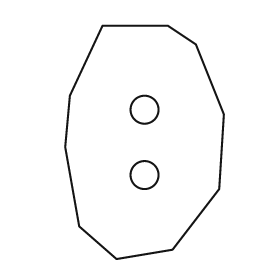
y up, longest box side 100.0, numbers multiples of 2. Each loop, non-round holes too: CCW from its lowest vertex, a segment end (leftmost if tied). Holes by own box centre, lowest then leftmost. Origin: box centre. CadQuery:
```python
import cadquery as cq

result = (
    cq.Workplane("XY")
    .moveTo(-12.0, -50.0)
    .lineTo(12.0, -46.0)
    .lineTo(32.0, -20.0)
    .lineTo(34.0, 12.0)
    .lineTo(22.0, 42.0)
    .lineTo(10.0, 50.0)
    .lineTo(-18.0, 50.0)
    .lineTo(-32.0, 20.0)
    .lineTo(-34.0, -2.0)
    .lineTo(-28.0, -36.0)
    .close()
    .moveTo(0.0, -14.0)
    .circle(6.0)
    .moveTo(0.0, 14.0)
    .circle(6.0)
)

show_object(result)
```